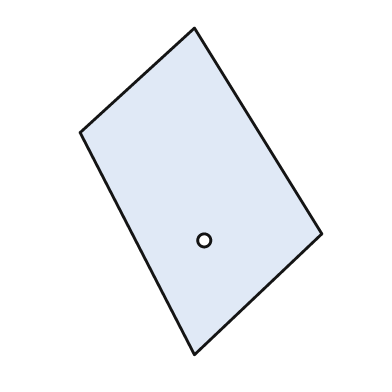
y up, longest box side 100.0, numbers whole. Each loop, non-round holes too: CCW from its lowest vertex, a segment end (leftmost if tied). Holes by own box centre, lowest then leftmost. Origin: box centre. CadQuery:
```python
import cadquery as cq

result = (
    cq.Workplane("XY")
    .moveTo(-2.0, -50.0)
    .lineTo(37.0, -13.0)
    .lineTo(-2.0, 50.0)
    .lineTo(-37.0, 18.0)
    .close()
    .moveTo(1.0, -15.0)
    .circle(2.0)
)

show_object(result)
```